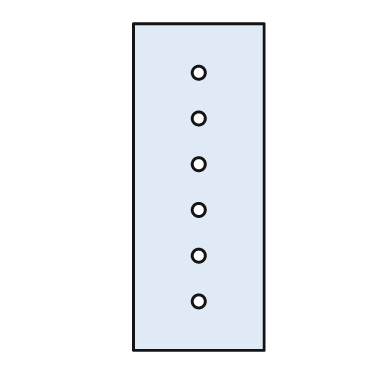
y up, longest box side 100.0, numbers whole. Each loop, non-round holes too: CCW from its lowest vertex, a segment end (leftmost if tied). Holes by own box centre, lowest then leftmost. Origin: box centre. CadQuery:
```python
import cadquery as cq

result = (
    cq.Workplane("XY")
    .moveTo(-20.0, -50.0)
    .lineTo(20.0, -50.0)
    .lineTo(20.0, 50.0)
    .lineTo(-20.0, 50.0)
    .close()
    .moveTo(0.0, -35.0)
    .circle(2.0)
    .moveTo(0.0, -21.0)
    .circle(2.0)
    .moveTo(0.0, -7.0)
    .circle(2.0)
    .moveTo(0.0, 7.0)
    .circle(2.0)
    .moveTo(0.0, 21.0)
    .circle(2.0)
    .moveTo(0.0, 35.0)
    .circle(2.0)
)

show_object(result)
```